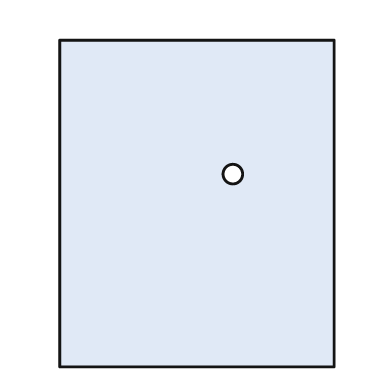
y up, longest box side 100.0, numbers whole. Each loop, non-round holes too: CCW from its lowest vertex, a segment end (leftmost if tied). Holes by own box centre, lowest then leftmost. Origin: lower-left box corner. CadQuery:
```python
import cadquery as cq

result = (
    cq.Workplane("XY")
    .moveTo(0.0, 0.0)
    .lineTo(84.0, 0.0)
    .lineTo(84.0, 100.0)
    .lineTo(0.0, 100.0)
    .close()
    .moveTo(53.0, 59.0)
    .circle(3.0)
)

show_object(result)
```